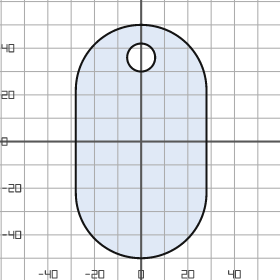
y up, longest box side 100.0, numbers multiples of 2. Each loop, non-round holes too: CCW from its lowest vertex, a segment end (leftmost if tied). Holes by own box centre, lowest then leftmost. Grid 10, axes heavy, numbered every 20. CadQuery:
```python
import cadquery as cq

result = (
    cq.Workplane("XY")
    .moveTo(-28.0, -22.0)
    .threePointArc((0.0, -50.0), (28.0, -22.0))
    .lineTo(28.0, 22.0)
    .threePointArc((0.0, 50.0), (-28.0, 22.0))
    .close()
    .moveTo(0.0, 36.0)
    .circle(6.0)
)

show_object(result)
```